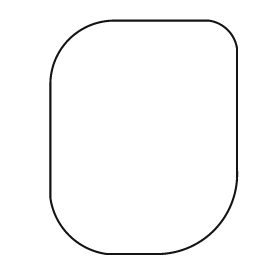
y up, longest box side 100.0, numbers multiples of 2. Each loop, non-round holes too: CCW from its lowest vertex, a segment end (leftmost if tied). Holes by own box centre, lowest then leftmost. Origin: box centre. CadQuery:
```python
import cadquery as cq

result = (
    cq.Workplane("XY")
    .moveTo(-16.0, -50.0)
    .lineTo(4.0, -50.0)
    .threePointArc((30.0, -40.0), (40.0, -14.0))
    .lineTo(40.0, 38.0)
    .threePointArc((36.0, 46.0), (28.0, 50.0))
    .lineTo(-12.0, 50.0)
    .threePointArc((-32.0, 42.0), (-40.0, 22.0))
    .lineTo(-40.0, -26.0)
    .threePointArc((-32.0, -42.0), (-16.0, -50.0))
    .close()
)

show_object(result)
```